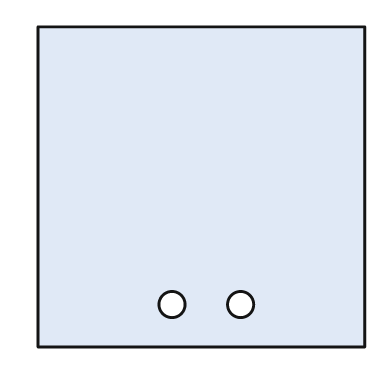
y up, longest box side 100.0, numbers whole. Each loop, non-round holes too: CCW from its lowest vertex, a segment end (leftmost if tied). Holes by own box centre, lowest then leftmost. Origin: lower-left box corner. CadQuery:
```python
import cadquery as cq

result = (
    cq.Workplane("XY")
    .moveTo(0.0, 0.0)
    .lineTo(100.0, 0.0)
    .lineTo(100.0, 98.0)
    .lineTo(0.0, 98.0)
    .close()
    .moveTo(41.0, 13.0)
    .circle(4.0)
    .moveTo(62.0, 13.0)
    .circle(4.0)
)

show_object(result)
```